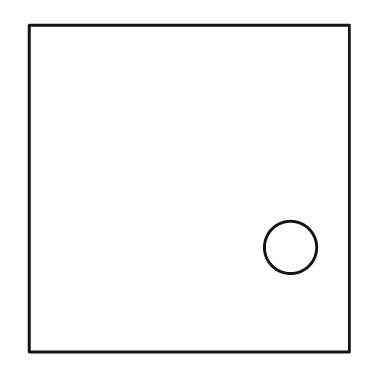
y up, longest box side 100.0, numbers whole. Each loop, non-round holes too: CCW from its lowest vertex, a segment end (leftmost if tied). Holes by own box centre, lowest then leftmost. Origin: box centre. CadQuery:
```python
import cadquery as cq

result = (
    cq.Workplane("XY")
    .moveTo(-49.0, -50.0)
    .lineTo(49.0, -50.0)
    .lineTo(49.0, 50.0)
    .lineTo(-49.0, 50.0)
    .close()
    .moveTo(31.0, -18.0)
    .circle(8.0)
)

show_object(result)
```